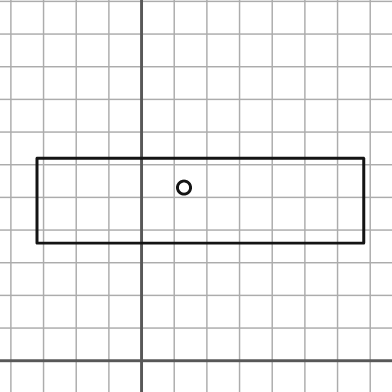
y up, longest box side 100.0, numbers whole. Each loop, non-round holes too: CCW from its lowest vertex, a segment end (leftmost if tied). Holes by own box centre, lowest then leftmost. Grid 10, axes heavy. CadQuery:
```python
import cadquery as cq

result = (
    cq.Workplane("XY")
    .moveTo(-32.0, 36.0)
    .lineTo(68.0, 36.0)
    .lineTo(68.0, 62.0)
    .lineTo(-32.0, 62.0)
    .close()
    .moveTo(13.0, 53.0)
    .circle(2.0)
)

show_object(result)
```